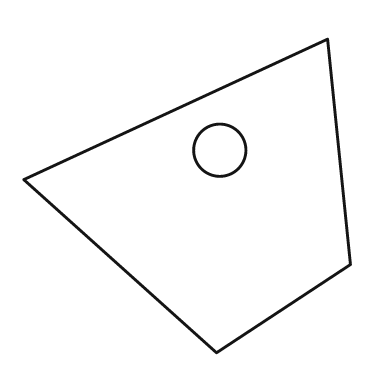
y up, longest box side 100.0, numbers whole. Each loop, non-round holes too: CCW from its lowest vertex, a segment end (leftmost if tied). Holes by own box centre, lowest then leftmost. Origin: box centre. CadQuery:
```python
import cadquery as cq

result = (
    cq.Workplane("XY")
    .moveTo(9.0, -48.0)
    .lineTo(50.0, -21.0)
    .lineTo(43.0, 48.0)
    .lineTo(-50.0, 5.0)
    .close()
    .moveTo(10.0, 14.0)
    .circle(8.0)
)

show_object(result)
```